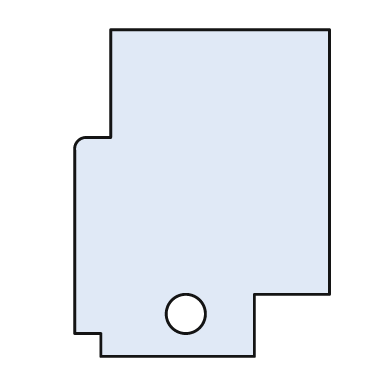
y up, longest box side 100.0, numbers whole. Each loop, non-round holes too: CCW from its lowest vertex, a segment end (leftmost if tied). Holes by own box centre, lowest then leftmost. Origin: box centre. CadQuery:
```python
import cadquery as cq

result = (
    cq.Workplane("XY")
    .moveTo(-31.0, -50.0)
    .lineTo(16.0, -50.0)
    .lineTo(16.0, -31.0)
    .lineTo(39.0, -31.0)
    .lineTo(39.0, 50.0)
    .lineTo(-28.0, 50.0)
    .lineTo(-28.0, 17.0)
    .lineTo(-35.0, 17.0)
    .threePointArc((-38.0, 16.0), (-39.0, 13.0))
    .lineTo(-39.0, -43.0)
    .lineTo(-31.0, -43.0)
    .close()
    .moveTo(-5.0, -37.0)
    .circle(6.0)
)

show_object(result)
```